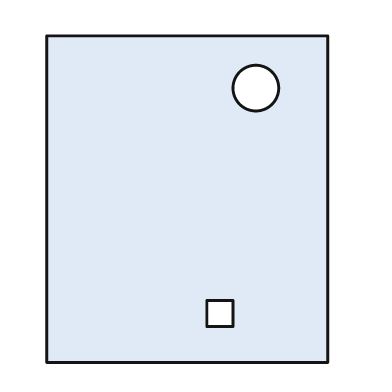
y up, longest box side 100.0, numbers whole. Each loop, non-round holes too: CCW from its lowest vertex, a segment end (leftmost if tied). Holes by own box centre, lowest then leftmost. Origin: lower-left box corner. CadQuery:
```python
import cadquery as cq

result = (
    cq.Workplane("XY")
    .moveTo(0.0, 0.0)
    .lineTo(86.0, 0.0)
    .lineTo(86.0, 100.0)
    .lineTo(0.0, 100.0)
    .close()
    .moveTo(49.0, 11.0)
    .lineTo(57.0, 11.0)
    .lineTo(57.0, 19.0)
    .lineTo(49.0, 19.0)
    .close()
    .moveTo(64.0, 84.0)
    .circle(7.0)
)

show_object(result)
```